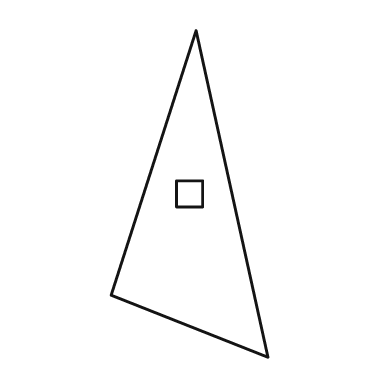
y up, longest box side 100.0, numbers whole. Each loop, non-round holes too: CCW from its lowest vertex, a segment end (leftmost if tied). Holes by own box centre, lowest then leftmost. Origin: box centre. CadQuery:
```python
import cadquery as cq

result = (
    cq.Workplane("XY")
    .moveTo(24.0, -50.0)
    .lineTo(2.0, 50.0)
    .lineTo(-24.0, -31.0)
    .close()
    .moveTo(-4.0, -4.0)
    .lineTo(4.0, -4.0)
    .lineTo(4.0, 4.0)
    .lineTo(-4.0, 4.0)
    .close()
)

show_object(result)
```